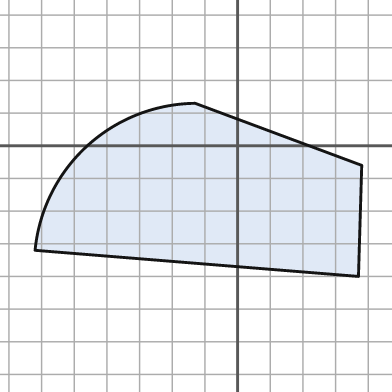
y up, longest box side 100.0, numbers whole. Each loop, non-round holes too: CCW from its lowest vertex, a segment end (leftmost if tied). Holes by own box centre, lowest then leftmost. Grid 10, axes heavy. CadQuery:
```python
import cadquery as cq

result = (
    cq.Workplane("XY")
    .moveTo(37.0, -40.0)
    .lineTo(38.0, -6.0)
    .lineTo(-13.0, 13.0)
    .threePointArc((-46.0, 0.0), (-62.0, -32.0))
    .close()
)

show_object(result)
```